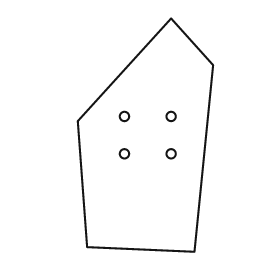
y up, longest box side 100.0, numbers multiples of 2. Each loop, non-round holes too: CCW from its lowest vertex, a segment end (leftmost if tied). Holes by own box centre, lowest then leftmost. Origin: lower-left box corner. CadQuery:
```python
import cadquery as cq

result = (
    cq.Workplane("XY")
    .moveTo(50.0, 0.0)
    .lineTo(58.0, 80.0)
    .lineTo(40.0, 100.0)
    .lineTo(0.0, 56.0)
    .lineTo(4.0, 2.0)
    .close()
    .moveTo(20.0, 42.0)
    .circle(2.0)
    .moveTo(40.0, 42.0)
    .circle(2.0)
    .moveTo(20.0, 58.0)
    .circle(2.0)
    .moveTo(40.0, 58.0)
    .circle(2.0)
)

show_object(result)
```